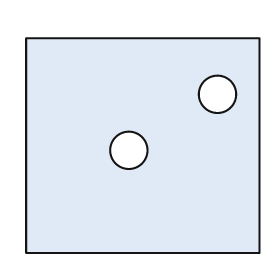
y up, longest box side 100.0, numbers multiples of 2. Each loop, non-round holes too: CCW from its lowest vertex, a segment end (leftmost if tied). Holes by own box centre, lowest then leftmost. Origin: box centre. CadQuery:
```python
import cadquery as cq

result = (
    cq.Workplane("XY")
    .moveTo(-50.0, -46.0)
    .lineTo(50.0, -46.0)
    .lineTo(50.0, 46.0)
    .lineTo(-50.0, 46.0)
    .close()
    .moveTo(-6.0, -2.0)
    .circle(8.0)
    .moveTo(32.0, 22.0)
    .circle(8.0)
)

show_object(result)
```